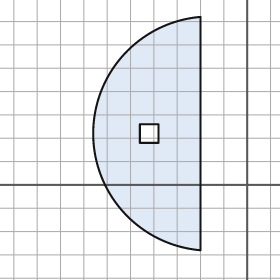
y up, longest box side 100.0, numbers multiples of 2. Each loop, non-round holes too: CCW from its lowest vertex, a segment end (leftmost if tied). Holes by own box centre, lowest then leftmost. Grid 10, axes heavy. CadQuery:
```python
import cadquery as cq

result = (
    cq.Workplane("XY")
    .moveTo(-20.0, -28.0)
    .lineTo(-20.0, 72.0)
    .threePointArc((-66.0, 22.0), (-20.0, -28.0))
    .close()
    .moveTo(-46.0, 18.0)
    .lineTo(-38.0, 18.0)
    .lineTo(-38.0, 26.0)
    .lineTo(-46.0, 26.0)
    .close()
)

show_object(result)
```